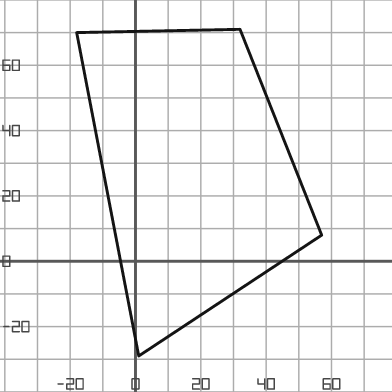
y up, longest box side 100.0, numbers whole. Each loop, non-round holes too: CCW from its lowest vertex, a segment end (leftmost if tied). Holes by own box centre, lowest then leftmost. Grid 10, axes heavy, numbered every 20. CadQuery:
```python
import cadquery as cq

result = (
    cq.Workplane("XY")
    .moveTo(1.0, -29.0)
    .lineTo(57.0, 8.0)
    .lineTo(32.0, 71.0)
    .lineTo(-18.0, 70.0)
    .close()
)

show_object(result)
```